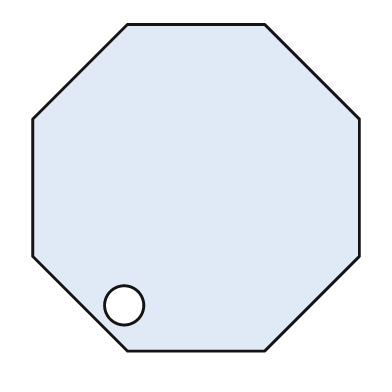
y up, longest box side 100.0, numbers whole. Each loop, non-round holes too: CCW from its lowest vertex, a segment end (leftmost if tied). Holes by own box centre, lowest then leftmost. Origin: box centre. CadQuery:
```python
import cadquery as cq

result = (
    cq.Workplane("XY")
    .moveTo(-21.0, -50.0)
    .lineTo(21.0, -50.0)
    .lineTo(50.0, -21.0)
    .lineTo(50.0, 21.0)
    .lineTo(21.0, 50.0)
    .lineTo(-21.0, 50.0)
    .lineTo(-50.0, 21.0)
    .lineTo(-50.0, -21.0)
    .close()
    .moveTo(-22.0, -36.0)
    .circle(6.0)
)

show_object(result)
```